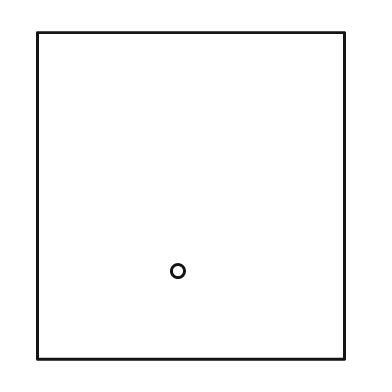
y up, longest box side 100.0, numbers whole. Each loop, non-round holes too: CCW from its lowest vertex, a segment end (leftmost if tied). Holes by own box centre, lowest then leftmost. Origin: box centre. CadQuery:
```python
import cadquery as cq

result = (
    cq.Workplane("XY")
    .moveTo(-47.0, -50.0)
    .lineTo(47.0, -50.0)
    .lineTo(47.0, 50.0)
    .lineTo(-47.0, 50.0)
    .close()
    .moveTo(-4.0, -23.0)
    .circle(2.0)
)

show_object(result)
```